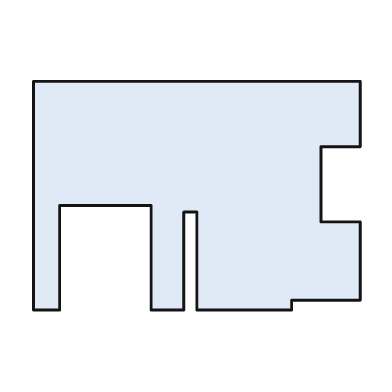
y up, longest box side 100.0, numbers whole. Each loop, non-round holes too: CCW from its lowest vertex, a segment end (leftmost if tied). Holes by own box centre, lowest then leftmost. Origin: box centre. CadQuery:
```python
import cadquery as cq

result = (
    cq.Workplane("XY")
    .moveTo(-50.0, -35.0)
    .lineTo(-42.0, -35.0)
    .lineTo(-42.0, -3.0)
    .lineTo(-14.0, -3.0)
    .lineTo(-14.0, -35.0)
    .lineTo(-4.0, -35.0)
    .lineTo(-4.0, -5.0)
    .lineTo(0.0, -5.0)
    .lineTo(0.0, -35.0)
    .lineTo(29.0, -35.0)
    .lineTo(29.0, -32.0)
    .lineTo(50.0, -32.0)
    .lineTo(50.0, -8.0)
    .lineTo(38.0, -8.0)
    .lineTo(38.0, 15.0)
    .lineTo(50.0, 15.0)
    .lineTo(50.0, 35.0)
    .lineTo(-50.0, 35.0)
    .close()
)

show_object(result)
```